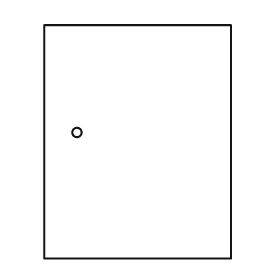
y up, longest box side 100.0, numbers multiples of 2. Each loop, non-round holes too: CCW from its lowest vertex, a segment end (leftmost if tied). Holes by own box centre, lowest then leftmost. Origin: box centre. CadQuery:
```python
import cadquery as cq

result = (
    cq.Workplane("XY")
    .moveTo(-40.0, -50.0)
    .lineTo(40.0, -50.0)
    .lineTo(40.0, 50.0)
    .lineTo(-40.0, 50.0)
    .close()
    .moveTo(-26.0, 4.0)
    .circle(2.0)
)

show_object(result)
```